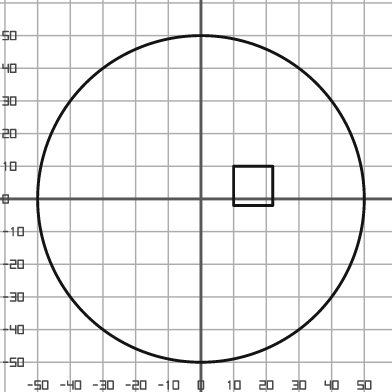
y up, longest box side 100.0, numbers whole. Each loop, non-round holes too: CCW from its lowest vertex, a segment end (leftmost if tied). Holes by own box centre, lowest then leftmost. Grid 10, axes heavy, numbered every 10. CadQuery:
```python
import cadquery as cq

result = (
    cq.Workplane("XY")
    .moveTo(0.0, 0.0)
    .circle(50.0)
    .moveTo(10.0, -2.0)
    .lineTo(22.0, -2.0)
    .lineTo(22.0, 10.0)
    .lineTo(10.0, 10.0)
    .close()
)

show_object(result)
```